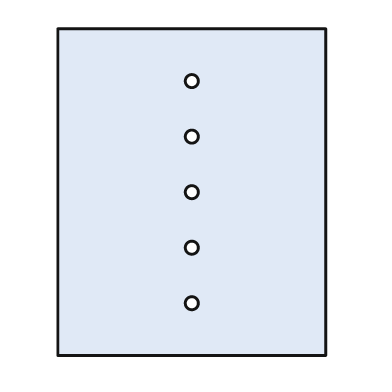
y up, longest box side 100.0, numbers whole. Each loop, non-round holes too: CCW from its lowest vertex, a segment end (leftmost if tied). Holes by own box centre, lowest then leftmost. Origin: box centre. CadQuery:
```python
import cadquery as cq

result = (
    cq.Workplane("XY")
    .moveTo(-41.0, -50.0)
    .lineTo(41.0, -50.0)
    .lineTo(41.0, 50.0)
    .lineTo(-41.0, 50.0)
    .close()
    .moveTo(0.0, -34.0)
    .circle(2.0)
    .moveTo(0.0, -17.0)
    .circle(2.0)
    .moveTo(0.0, 0.0)
    .circle(2.0)
    .moveTo(0.0, 17.0)
    .circle(2.0)
    .moveTo(0.0, 34.0)
    .circle(2.0)
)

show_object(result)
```